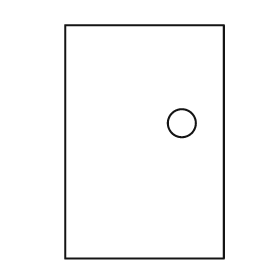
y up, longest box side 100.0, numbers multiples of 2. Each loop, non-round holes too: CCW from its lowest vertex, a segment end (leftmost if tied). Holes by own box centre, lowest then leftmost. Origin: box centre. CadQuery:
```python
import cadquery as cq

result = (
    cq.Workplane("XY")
    .moveTo(-34.0, -50.0)
    .lineTo(34.0, -50.0)
    .lineTo(34.0, 50.0)
    .lineTo(-34.0, 50.0)
    .close()
    .moveTo(16.0, 8.0)
    .circle(6.0)
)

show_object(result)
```